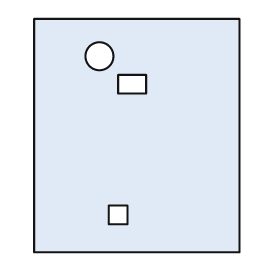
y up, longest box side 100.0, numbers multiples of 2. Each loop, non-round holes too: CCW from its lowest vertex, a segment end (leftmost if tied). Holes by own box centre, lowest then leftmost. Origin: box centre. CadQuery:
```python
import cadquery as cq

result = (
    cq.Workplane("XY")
    .moveTo(-44.0, -50.0)
    .lineTo(44.0, -50.0)
    .lineTo(44.0, 50.0)
    .lineTo(-44.0, 50.0)
    .close()
    .moveTo(-12.0, -38.0)
    .lineTo(-4.0, -38.0)
    .lineTo(-4.0, -30.0)
    .lineTo(-12.0, -30.0)
    .close()
    .moveTo(-8.0, 18.0)
    .lineTo(4.0, 18.0)
    .lineTo(4.0, 26.0)
    .lineTo(-8.0, 26.0)
    .close()
    .moveTo(-16.0, 34.0)
    .circle(6.0)
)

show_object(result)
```